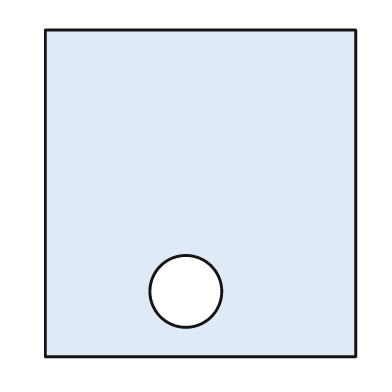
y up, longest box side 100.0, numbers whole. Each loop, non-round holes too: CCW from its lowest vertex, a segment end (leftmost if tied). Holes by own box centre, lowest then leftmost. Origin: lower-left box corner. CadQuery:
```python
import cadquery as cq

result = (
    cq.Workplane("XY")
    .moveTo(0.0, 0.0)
    .lineTo(95.0, 0.0)
    .lineTo(95.0, 100.0)
    .lineTo(0.0, 100.0)
    .close()
    .moveTo(43.0, 20.0)
    .circle(11.0)
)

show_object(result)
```